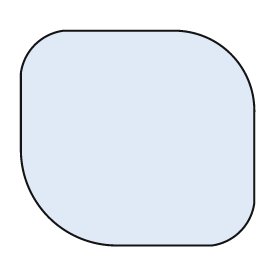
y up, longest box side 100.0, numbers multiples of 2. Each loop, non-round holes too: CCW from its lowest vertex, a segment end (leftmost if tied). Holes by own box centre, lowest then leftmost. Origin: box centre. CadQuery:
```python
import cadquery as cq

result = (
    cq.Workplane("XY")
    .moveTo(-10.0, -46.0)
    .lineTo(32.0, -46.0)
    .threePointArc((44.0, -40.0), (50.0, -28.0))
    .lineTo(50.0, 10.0)
    .threePointArc((40.0, 36.0), (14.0, 46.0))
    .lineTo(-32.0, 46.0)
    .threePointArc((-44.0, 40.0), (-50.0, 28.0))
    .lineTo(-50.0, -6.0)
    .threePointArc((-38.0, -34.0), (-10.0, -46.0))
    .close()
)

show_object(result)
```